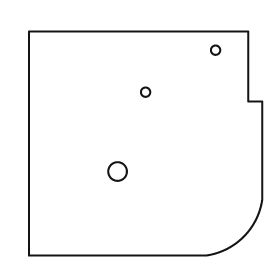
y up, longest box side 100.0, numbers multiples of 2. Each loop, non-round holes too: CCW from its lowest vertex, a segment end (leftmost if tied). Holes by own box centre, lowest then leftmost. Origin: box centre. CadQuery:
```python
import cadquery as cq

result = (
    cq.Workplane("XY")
    .moveTo(-50.0, -48.0)
    .lineTo(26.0, -48.0)
    .threePointArc((42.0, -40.0), (50.0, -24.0))
    .lineTo(50.0, 18.0)
    .lineTo(44.0, 18.0)
    .lineTo(44.0, 48.0)
    .lineTo(-50.0, 48.0)
    .close()
    .moveTo(-12.0, -12.0)
    .circle(4.0)
    .moveTo(0.0, 22.0)
    .circle(2.0)
    .moveTo(30.0, 40.0)
    .circle(2.0)
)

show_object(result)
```